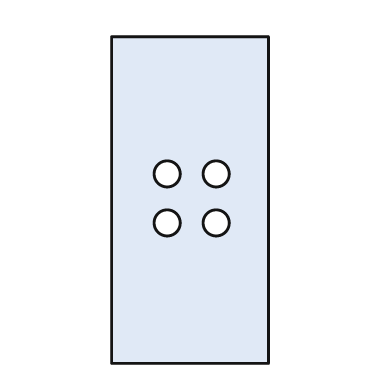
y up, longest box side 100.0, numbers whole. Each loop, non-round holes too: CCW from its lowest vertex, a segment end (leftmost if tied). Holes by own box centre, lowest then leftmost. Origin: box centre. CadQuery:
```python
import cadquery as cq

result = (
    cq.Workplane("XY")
    .moveTo(-24.0, -50.0)
    .lineTo(24.0, -50.0)
    .lineTo(24.0, 50.0)
    .lineTo(-24.0, 50.0)
    .close()
    .moveTo(-7.0, -7.0)
    .circle(4.0)
    .moveTo(8.0, -7.0)
    .circle(4.0)
    .moveTo(-7.0, 8.0)
    .circle(4.0)
    .moveTo(8.0, 8.0)
    .circle(4.0)
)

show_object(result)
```